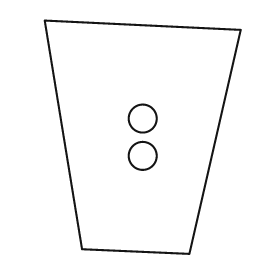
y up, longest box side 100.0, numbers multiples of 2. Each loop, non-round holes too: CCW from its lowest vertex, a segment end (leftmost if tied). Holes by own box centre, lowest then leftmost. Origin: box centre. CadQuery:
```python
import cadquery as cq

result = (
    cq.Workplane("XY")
    .moveTo(20.0, -50.0)
    .lineTo(42.0, 46.0)
    .lineTo(-42.0, 50.0)
    .lineTo(-26.0, -48.0)
    .close()
    .moveTo(0.0, -8.0)
    .circle(6.0)
    .moveTo(0.0, 8.0)
    .circle(6.0)
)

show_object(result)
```